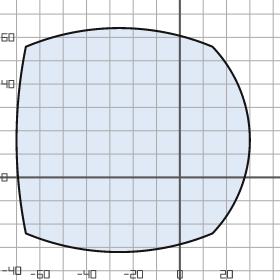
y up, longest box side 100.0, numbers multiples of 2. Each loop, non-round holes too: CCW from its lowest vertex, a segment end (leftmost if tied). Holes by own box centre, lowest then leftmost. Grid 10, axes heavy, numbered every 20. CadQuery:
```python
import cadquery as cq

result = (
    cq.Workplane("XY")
    .moveTo(-66.0, -24.0)
    .threePointArc((-26.0, -32.0), (14.0, -24.0))
    .threePointArc((30.0, 16.0), (14.0, 56.0))
    .threePointArc((-26.0, 64.0), (-66.0, 56.0))
    .threePointArc((-70.0, 16.0), (-66.0, -24.0))
    .close()
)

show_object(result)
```